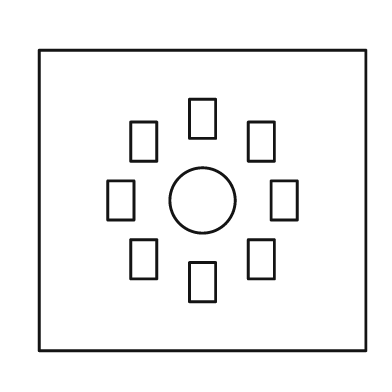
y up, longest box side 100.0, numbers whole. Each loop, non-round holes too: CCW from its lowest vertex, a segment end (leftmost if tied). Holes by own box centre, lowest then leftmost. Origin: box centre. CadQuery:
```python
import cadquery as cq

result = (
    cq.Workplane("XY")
    .moveTo(-50.0, -46.0)
    .lineTo(50.0, -46.0)
    .lineTo(50.0, 46.0)
    .lineTo(-50.0, 46.0)
    .close()
    .moveTo(-4.0, -31.0)
    .lineTo(4.0, -31.0)
    .lineTo(4.0, -19.0)
    .lineTo(-4.0, -19.0)
    .close()
    .moveTo(-22.0, -24.0)
    .lineTo(-14.0, -24.0)
    .lineTo(-14.0, -12.0)
    .lineTo(-22.0, -12.0)
    .close()
    .moveTo(14.0, -24.0)
    .lineTo(22.0, -24.0)
    .lineTo(22.0, -12.0)
    .lineTo(14.0, -12.0)
    .close()
    .moveTo(-29.0, -6.0)
    .lineTo(-21.0, -6.0)
    .lineTo(-21.0, 6.0)
    .lineTo(-29.0, 6.0)
    .close()
    .moveTo(0.0, 0.0)
    .circle(10.0)
    .moveTo(21.0, -6.0)
    .lineTo(29.0, -6.0)
    .lineTo(29.0, 6.0)
    .lineTo(21.0, 6.0)
    .close()
    .moveTo(-22.0, 12.0)
    .lineTo(-14.0, 12.0)
    .lineTo(-14.0, 24.0)
    .lineTo(-22.0, 24.0)
    .close()
    .moveTo(14.0, 12.0)
    .lineTo(22.0, 12.0)
    .lineTo(22.0, 24.0)
    .lineTo(14.0, 24.0)
    .close()
    .moveTo(-4.0, 19.0)
    .lineTo(4.0, 19.0)
    .lineTo(4.0, 31.0)
    .lineTo(-4.0, 31.0)
    .close()
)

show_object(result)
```